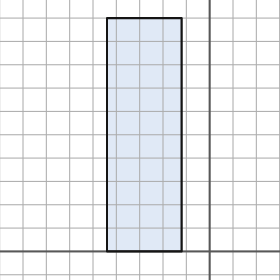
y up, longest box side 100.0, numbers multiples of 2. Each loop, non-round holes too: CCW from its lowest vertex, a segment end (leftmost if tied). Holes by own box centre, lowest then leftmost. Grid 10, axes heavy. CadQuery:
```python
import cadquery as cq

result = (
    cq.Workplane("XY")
    .moveTo(-44.0, 0.0)
    .lineTo(-12.0, 0.0)
    .lineTo(-12.0, 100.0)
    .lineTo(-44.0, 100.0)
    .close()
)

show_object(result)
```